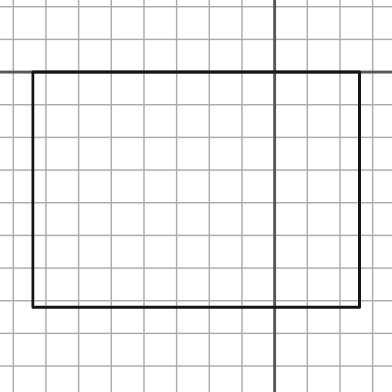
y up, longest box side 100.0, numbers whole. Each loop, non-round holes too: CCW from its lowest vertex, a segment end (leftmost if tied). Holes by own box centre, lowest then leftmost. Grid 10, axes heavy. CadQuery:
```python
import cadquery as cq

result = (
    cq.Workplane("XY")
    .moveTo(-74.0, -72.0)
    .lineTo(26.0, -72.0)
    .lineTo(26.0, 0.0)
    .lineTo(-74.0, 0.0)
    .close()
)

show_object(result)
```